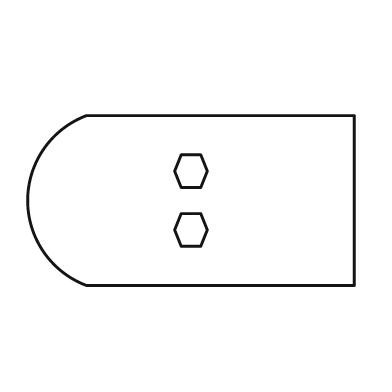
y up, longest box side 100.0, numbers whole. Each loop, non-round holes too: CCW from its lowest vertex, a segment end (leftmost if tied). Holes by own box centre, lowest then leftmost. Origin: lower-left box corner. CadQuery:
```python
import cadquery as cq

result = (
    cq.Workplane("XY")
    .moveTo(18.0, 0.0)
    .lineTo(100.0, 0.0)
    .lineTo(100.0, 52.0)
    .lineTo(18.0, 52.0)
    .threePointArc((0.0, 26.0), (18.0, 0.0))
    .close()
    .moveTo(47.0, 12.0)
    .lineTo(53.0, 12.0)
    .lineTo(55.0, 17.0)
    .lineTo(53.0, 22.0)
    .lineTo(47.0, 22.0)
    .lineTo(45.0, 17.0)
    .close()
    .moveTo(47.0, 30.0)
    .lineTo(53.0, 30.0)
    .lineTo(55.0, 35.0)
    .lineTo(53.0, 40.0)
    .lineTo(47.0, 40.0)
    .lineTo(45.0, 35.0)
    .close()
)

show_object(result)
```